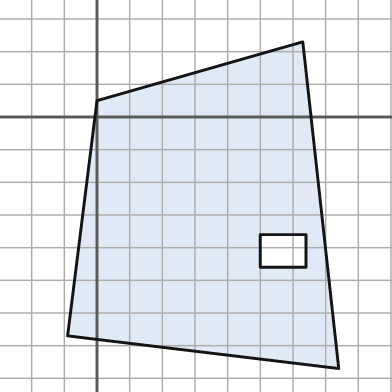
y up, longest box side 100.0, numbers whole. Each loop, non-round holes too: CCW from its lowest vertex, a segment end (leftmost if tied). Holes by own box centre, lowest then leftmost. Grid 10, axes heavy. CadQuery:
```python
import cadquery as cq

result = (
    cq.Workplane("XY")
    .moveTo(74.0, -77.0)
    .lineTo(63.0, 23.0)
    .lineTo(0.0, 5.0)
    .lineTo(-9.0, -67.0)
    .close()
    .moveTo(50.0, -46.0)
    .lineTo(64.0, -46.0)
    .lineTo(64.0, -36.0)
    .lineTo(50.0, -36.0)
    .close()
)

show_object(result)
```